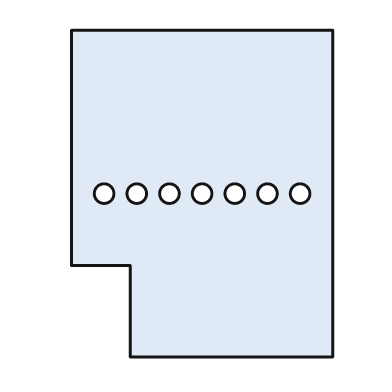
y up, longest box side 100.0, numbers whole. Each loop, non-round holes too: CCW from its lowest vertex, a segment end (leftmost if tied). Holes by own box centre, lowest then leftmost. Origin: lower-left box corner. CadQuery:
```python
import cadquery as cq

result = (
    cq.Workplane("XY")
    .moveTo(18.0, 0.0)
    .lineTo(80.0, 0.0)
    .lineTo(80.0, 100.0)
    .lineTo(0.0, 100.0)
    .lineTo(0.0, 28.0)
    .lineTo(18.0, 28.0)
    .close()
    .moveTo(10.0, 50.0)
    .circle(3.0)
    .moveTo(20.0, 50.0)
    .circle(3.0)
    .moveTo(30.0, 50.0)
    .circle(3.0)
    .moveTo(40.0, 50.0)
    .circle(3.0)
    .moveTo(50.0, 50.0)
    .circle(3.0)
    .moveTo(60.0, 50.0)
    .circle(3.0)
    .moveTo(70.0, 50.0)
    .circle(3.0)
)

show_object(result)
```